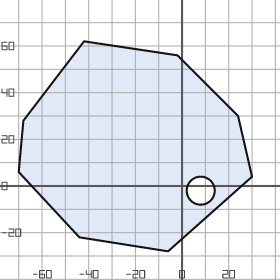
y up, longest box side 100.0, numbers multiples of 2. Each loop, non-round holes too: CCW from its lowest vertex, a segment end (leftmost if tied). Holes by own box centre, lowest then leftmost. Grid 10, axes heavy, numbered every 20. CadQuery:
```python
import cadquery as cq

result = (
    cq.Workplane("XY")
    .moveTo(-6.0, -28.0)
    .lineTo(30.0, 4.0)
    .lineTo(24.0, 30.0)
    .lineTo(-2.0, 56.0)
    .lineTo(-42.0, 62.0)
    .lineTo(-68.0, 28.0)
    .lineTo(-70.0, 6.0)
    .lineTo(-44.0, -22.0)
    .close()
    .moveTo(8.0, -2.0)
    .circle(6.0)
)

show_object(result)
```